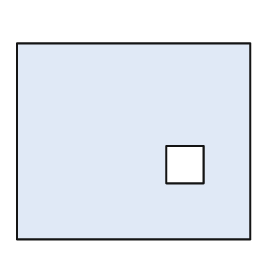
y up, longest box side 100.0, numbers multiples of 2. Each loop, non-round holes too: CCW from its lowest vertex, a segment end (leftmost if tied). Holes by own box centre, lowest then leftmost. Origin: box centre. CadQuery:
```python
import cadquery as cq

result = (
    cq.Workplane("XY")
    .moveTo(-50.0, -42.0)
    .lineTo(50.0, -42.0)
    .lineTo(50.0, 42.0)
    .lineTo(-50.0, 42.0)
    .close()
    .moveTo(14.0, -18.0)
    .lineTo(30.0, -18.0)
    .lineTo(30.0, -2.0)
    .lineTo(14.0, -2.0)
    .close()
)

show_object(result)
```